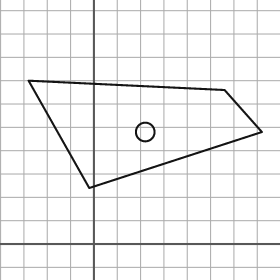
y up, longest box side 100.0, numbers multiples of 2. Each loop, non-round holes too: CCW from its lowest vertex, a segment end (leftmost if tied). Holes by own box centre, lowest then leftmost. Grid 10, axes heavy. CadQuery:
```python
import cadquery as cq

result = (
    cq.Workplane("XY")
    .moveTo(-2.0, 24.0)
    .lineTo(72.0, 48.0)
    .lineTo(56.0, 66.0)
    .lineTo(-28.0, 70.0)
    .close()
    .moveTo(22.0, 48.0)
    .circle(4.0)
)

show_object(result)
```